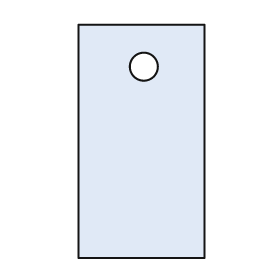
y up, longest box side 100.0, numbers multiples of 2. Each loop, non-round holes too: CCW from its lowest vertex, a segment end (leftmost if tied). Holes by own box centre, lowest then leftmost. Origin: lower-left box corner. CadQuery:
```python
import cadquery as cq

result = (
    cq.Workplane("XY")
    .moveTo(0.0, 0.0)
    .lineTo(54.0, 0.0)
    .lineTo(54.0, 100.0)
    .lineTo(0.0, 100.0)
    .close()
    .moveTo(28.0, 82.0)
    .circle(6.0)
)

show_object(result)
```